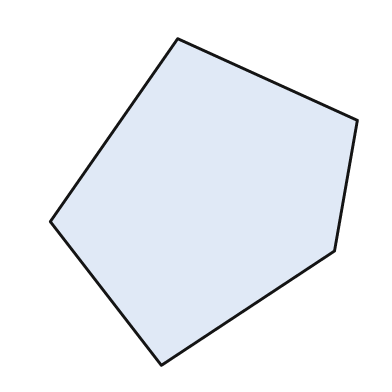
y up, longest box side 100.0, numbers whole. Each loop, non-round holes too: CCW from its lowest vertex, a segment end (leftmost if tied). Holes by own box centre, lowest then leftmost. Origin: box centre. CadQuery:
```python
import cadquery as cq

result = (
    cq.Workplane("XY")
    .moveTo(-13.0, -50.0)
    .lineTo(40.0, -15.0)
    .lineTo(47.0, 25.0)
    .lineTo(-8.0, 50.0)
    .lineTo(-47.0, -6.0)
    .close()
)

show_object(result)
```